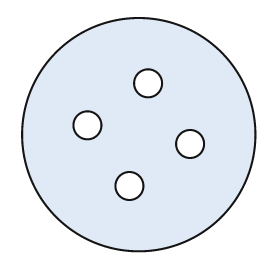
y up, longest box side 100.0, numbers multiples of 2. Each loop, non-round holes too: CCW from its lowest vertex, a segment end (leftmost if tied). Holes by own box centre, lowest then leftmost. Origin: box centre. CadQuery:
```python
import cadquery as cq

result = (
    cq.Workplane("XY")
    .moveTo(0.0, 0.0)
    .circle(50.0)
    .moveTo(-4.0, -22.0)
    .circle(6.0)
    .moveTo(22.0, -4.0)
    .circle(6.0)
    .moveTo(-22.0, 4.0)
    .circle(6.0)
    .moveTo(4.0, 22.0)
    .circle(6.0)
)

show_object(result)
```